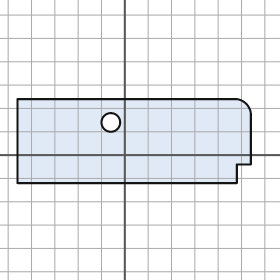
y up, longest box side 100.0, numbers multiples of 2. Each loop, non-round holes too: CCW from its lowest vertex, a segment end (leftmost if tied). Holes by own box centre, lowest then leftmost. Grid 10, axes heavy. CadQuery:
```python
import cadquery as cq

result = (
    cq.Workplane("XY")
    .moveTo(-46.0, -12.0)
    .lineTo(48.0, -12.0)
    .lineTo(48.0, -4.0)
    .lineTo(54.0, -4.0)
    .lineTo(54.0, 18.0)
    .threePointArc((52.0, 22.0), (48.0, 24.0))
    .lineTo(-46.0, 24.0)
    .close()
    .moveTo(-6.0, 14.0)
    .circle(4.0)
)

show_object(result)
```